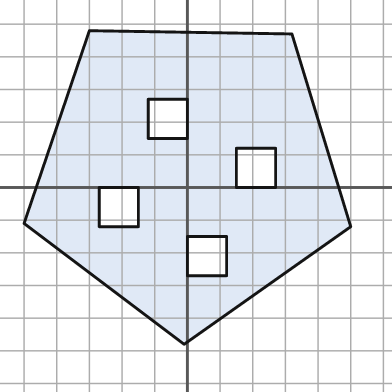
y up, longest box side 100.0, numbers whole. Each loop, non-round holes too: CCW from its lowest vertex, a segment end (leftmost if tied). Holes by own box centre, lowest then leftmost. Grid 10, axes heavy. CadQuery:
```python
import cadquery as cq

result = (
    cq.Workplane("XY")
    .moveTo(-1.0, -48.0)
    .lineTo(50.0, -12.0)
    .lineTo(32.0, 47.0)
    .lineTo(-30.0, 48.0)
    .lineTo(-50.0, -11.0)
    .close()
    .moveTo(0.0, -27.0)
    .lineTo(12.0, -27.0)
    .lineTo(12.0, -15.0)
    .lineTo(0.0, -15.0)
    .close()
    .moveTo(-27.0, -12.0)
    .lineTo(-15.0, -12.0)
    .lineTo(-15.0, 0.0)
    .lineTo(-27.0, 0.0)
    .close()
    .moveTo(15.0, 0.0)
    .lineTo(27.0, 0.0)
    .lineTo(27.0, 12.0)
    .lineTo(15.0, 12.0)
    .close()
    .moveTo(-12.0, 15.0)
    .lineTo(0.0, 15.0)
    .lineTo(0.0, 27.0)
    .lineTo(-12.0, 27.0)
    .close()
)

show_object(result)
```